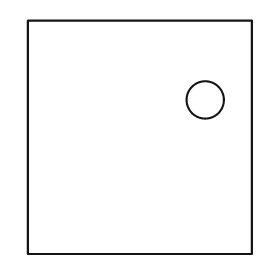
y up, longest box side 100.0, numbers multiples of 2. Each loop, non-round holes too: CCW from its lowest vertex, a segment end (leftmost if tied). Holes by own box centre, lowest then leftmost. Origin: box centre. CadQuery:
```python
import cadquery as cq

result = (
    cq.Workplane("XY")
    .moveTo(-48.0, -50.0)
    .lineTo(48.0, -50.0)
    .lineTo(48.0, 50.0)
    .lineTo(-48.0, 50.0)
    .close()
    .moveTo(28.0, 16.0)
    .circle(8.0)
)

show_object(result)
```